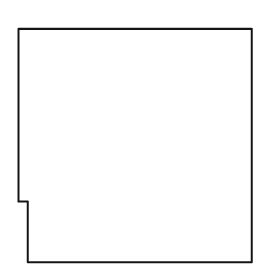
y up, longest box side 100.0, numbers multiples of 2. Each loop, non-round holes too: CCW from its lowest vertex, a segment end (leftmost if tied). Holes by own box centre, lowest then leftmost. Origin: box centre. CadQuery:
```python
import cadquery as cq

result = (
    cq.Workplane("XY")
    .moveTo(-46.0, -50.0)
    .lineTo(50.0, -50.0)
    .lineTo(50.0, 50.0)
    .lineTo(-50.0, 50.0)
    .lineTo(-50.0, -24.0)
    .lineTo(-46.0, -24.0)
    .close()
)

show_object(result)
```